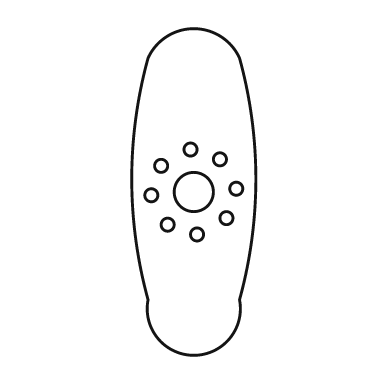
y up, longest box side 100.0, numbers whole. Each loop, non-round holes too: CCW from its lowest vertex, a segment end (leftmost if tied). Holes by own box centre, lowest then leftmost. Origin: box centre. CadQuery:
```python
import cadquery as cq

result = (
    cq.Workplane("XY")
    .moveTo(-14.0, -33.0)
    .threePointArc((0.0, -50.0), (14.0, -33.0))
    .threePointArc((19.0, 4.0), (14.0, 41.0))
    .threePointArc((0.0, 50.0), (-14.0, 41.0))
    .threePointArc((-19.0, 4.0), (-14.0, -33.0))
    .close()
    .moveTo(1.0, -13.0)
    .circle(2.0)
    .moveTo(-8.0, -10.0)
    .circle(2.0)
    .moveTo(10.0, -8.0)
    .circle(2.0)
    .moveTo(-13.0, -1.0)
    .circle(2.0)
    .moveTo(0.0, 0.0)
    .circle(6.0)
    .moveTo(13.0, 1.0)
    .circle(2.0)
    .moveTo(-10.0, 8.0)
    .circle(2.0)
    .moveTo(8.0, 10.0)
    .circle(2.0)
    .moveTo(-1.0, 13.0)
    .circle(2.0)
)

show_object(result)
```